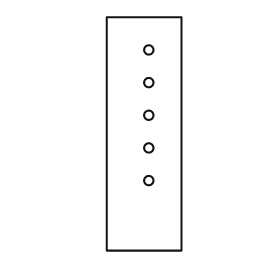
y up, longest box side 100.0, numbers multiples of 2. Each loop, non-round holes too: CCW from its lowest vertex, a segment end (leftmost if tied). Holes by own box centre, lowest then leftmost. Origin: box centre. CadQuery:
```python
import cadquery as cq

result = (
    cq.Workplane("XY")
    .moveTo(-16.0, -50.0)
    .lineTo(16.0, -50.0)
    .lineTo(16.0, 50.0)
    .lineTo(-16.0, 50.0)
    .close()
    .moveTo(2.0, -20.0)
    .circle(2.0)
    .moveTo(2.0, -6.0)
    .circle(2.0)
    .moveTo(2.0, 8.0)
    .circle(2.0)
    .moveTo(2.0, 22.0)
    .circle(2.0)
    .moveTo(2.0, 36.0)
    .circle(2.0)
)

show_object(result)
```